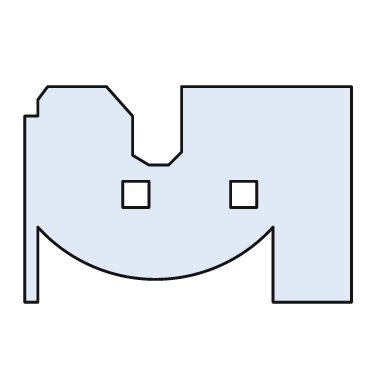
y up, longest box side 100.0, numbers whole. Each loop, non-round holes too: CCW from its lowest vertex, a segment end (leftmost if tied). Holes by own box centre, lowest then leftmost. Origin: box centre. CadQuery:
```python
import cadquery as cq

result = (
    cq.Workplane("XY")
    .moveTo(-50.0, -33.0)
    .lineTo(-46.0, -33.0)
    .lineTo(-46.0, -10.0)
    .threePointArc((-10.0, -26.0), (26.0, -10.0))
    .lineTo(26.0, -33.0)
    .lineTo(50.0, -33.0)
    .lineTo(50.0, 33.0)
    .lineTo(-2.0, 33.0)
    .lineTo(-2.0, 13.0)
    .lineTo(-6.0, 9.0)
    .lineTo(-12.0, 9.0)
    .lineTo(-17.0, 12.0)
    .lineTo(-17.0, 24.0)
    .lineTo(-25.0, 33.0)
    .lineTo(-43.0, 33.0)
    .lineTo(-46.0, 29.0)
    .lineTo(-46.0, 24.0)
    .lineTo(-50.0, 24.0)
    .close()
    .moveTo(-20.0, -4.0)
    .lineTo(-12.0, -4.0)
    .lineTo(-12.0, 4.0)
    .lineTo(-20.0, 4.0)
    .close()
    .moveTo(13.0, -4.0)
    .lineTo(21.0, -4.0)
    .lineTo(21.0, 4.0)
    .lineTo(13.0, 4.0)
    .close()
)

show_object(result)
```